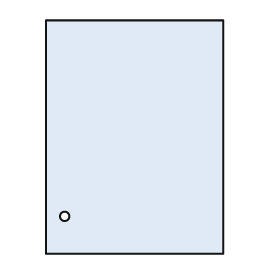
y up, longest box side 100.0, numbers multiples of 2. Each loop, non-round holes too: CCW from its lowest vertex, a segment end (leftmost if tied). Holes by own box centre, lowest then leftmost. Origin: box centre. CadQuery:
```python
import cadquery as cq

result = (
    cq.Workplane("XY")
    .moveTo(-38.0, -50.0)
    .lineTo(38.0, -50.0)
    .lineTo(38.0, 50.0)
    .lineTo(-38.0, 50.0)
    .close()
    .moveTo(-30.0, -34.0)
    .circle(2.0)
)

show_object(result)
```